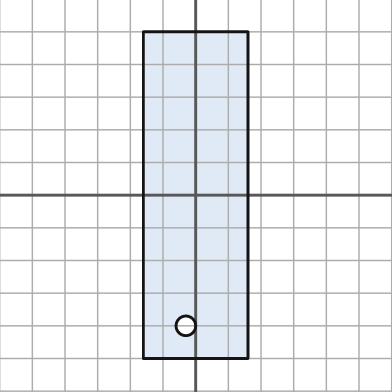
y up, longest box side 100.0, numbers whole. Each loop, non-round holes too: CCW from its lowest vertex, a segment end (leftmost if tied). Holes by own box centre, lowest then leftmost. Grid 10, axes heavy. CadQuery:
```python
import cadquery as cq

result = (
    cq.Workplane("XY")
    .moveTo(-16.0, -50.0)
    .lineTo(16.0, -50.0)
    .lineTo(16.0, 50.0)
    .lineTo(-16.0, 50.0)
    .close()
    .moveTo(-3.0, -40.0)
    .circle(3.0)
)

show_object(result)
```